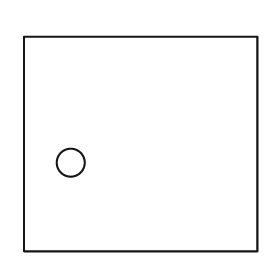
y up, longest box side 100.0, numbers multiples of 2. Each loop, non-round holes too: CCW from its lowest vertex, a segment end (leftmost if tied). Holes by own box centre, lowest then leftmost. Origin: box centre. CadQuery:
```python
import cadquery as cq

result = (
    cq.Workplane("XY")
    .moveTo(-50.0, -46.0)
    .lineTo(50.0, -46.0)
    .lineTo(50.0, 46.0)
    .lineTo(-50.0, 46.0)
    .close()
    .moveTo(-30.0, -8.0)
    .circle(6.0)
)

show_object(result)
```